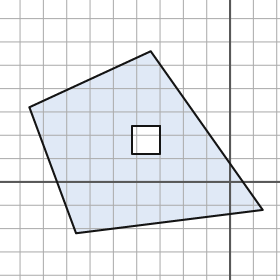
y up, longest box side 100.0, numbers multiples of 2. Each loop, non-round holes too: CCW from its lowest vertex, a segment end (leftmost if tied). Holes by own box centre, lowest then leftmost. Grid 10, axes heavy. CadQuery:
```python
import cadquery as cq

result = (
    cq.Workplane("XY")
    .moveTo(-66.0, -22.0)
    .lineTo(14.0, -12.0)
    .lineTo(-34.0, 56.0)
    .lineTo(-86.0, 32.0)
    .close()
    .moveTo(-42.0, 12.0)
    .lineTo(-30.0, 12.0)
    .lineTo(-30.0, 24.0)
    .lineTo(-42.0, 24.0)
    .close()
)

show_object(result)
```